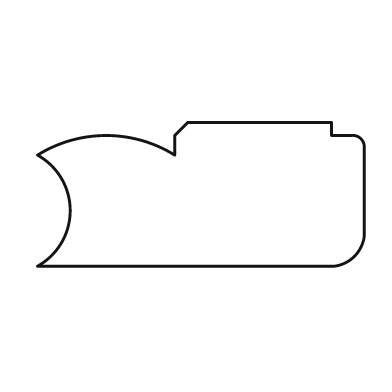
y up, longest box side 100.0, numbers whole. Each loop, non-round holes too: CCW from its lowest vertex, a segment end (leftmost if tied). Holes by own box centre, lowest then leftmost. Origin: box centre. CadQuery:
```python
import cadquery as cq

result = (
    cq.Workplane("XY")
    .moveTo(-50.0, -22.0)
    .lineTo(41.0, -22.0)
    .threePointArc((47.0, -19.0), (50.0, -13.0))
    .lineTo(50.0, 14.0)
    .threePointArc((49.0, 17.0), (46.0, 18.0))
    .lineTo(40.0, 18.0)
    .lineTo(40.0, 22.0)
    .lineTo(-4.0, 22.0)
    .lineTo(-8.0, 18.0)
    .lineTo(-8.0, 12.0)
    .threePointArc((-29.0, 18.0), (-50.0, 12.0))
    .threePointArc((-40.0, -5.0), (-50.0, -22.0))
    .close()
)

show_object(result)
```